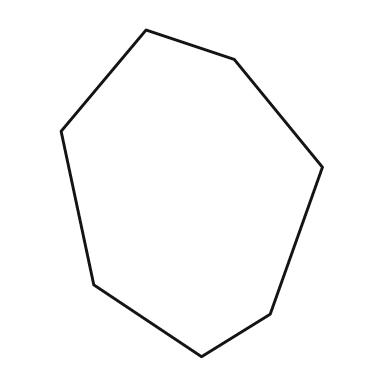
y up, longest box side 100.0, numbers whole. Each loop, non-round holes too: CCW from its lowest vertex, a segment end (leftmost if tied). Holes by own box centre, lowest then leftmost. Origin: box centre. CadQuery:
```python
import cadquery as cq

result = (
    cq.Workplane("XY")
    .moveTo(3.0, -50.0)
    .lineTo(24.0, -37.0)
    .lineTo(40.0, 8.0)
    .lineTo(13.0, 41.0)
    .lineTo(-14.0, 50.0)
    .lineTo(-40.0, 19.0)
    .lineTo(-30.0, -28.0)
    .close()
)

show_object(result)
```